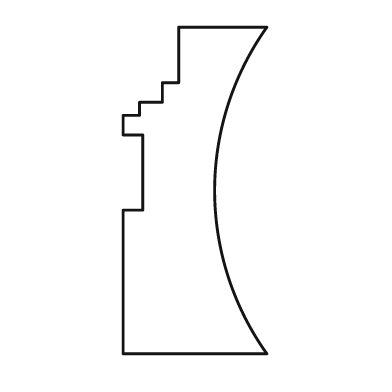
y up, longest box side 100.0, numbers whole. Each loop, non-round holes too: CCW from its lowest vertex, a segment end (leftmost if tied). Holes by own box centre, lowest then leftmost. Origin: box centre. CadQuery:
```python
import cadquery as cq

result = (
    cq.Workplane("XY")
    .moveTo(-22.0, -50.0)
    .lineTo(22.0, -50.0)
    .threePointArc((6.0, 0.0), (22.0, 50.0))
    .lineTo(-5.0, 50.0)
    .lineTo(-5.0, 33.0)
    .lineTo(-10.0, 33.0)
    .lineTo(-10.0, 27.0)
    .lineTo(-17.0, 27.0)
    .lineTo(-17.0, 23.0)
    .lineTo(-22.0, 23.0)
    .lineTo(-22.0, 17.0)
    .lineTo(-16.0, 17.0)
    .lineTo(-16.0, -6.0)
    .lineTo(-22.0, -6.0)
    .close()
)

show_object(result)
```